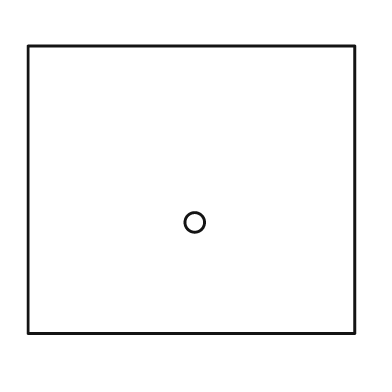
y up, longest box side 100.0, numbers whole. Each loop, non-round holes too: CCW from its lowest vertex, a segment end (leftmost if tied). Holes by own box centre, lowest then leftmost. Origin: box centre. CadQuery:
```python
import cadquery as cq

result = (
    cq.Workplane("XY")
    .moveTo(-50.0, -44.0)
    .lineTo(50.0, -44.0)
    .lineTo(50.0, 44.0)
    .lineTo(-50.0, 44.0)
    .close()
    .moveTo(1.0, -10.0)
    .circle(3.0)
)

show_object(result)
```